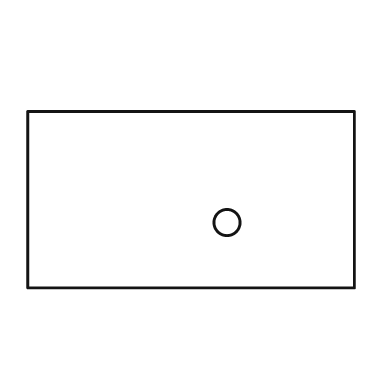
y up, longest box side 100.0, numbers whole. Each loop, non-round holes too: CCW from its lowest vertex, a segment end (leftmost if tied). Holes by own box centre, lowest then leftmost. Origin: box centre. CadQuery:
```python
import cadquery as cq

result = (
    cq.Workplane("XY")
    .moveTo(-50.0, -27.0)
    .lineTo(50.0, -27.0)
    .lineTo(50.0, 27.0)
    .lineTo(-50.0, 27.0)
    .close()
    .moveTo(11.0, -7.0)
    .circle(4.0)
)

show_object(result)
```